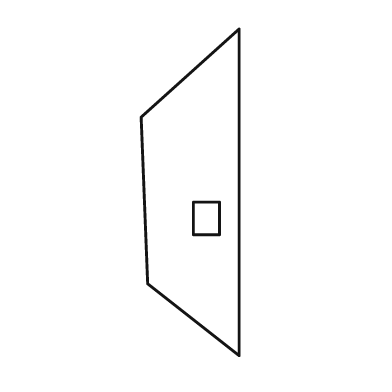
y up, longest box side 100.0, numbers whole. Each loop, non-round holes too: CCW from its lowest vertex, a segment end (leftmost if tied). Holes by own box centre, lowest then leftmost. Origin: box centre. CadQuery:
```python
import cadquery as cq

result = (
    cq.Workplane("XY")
    .moveTo(15.0, -50.0)
    .lineTo(15.0, 50.0)
    .lineTo(-15.0, 23.0)
    .lineTo(-13.0, -28.0)
    .close()
    .moveTo(1.0, -13.0)
    .lineTo(9.0, -13.0)
    .lineTo(9.0, -3.0)
    .lineTo(1.0, -3.0)
    .close()
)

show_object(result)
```